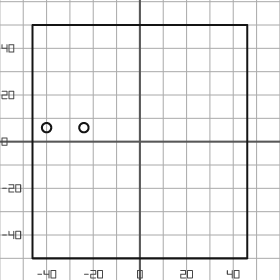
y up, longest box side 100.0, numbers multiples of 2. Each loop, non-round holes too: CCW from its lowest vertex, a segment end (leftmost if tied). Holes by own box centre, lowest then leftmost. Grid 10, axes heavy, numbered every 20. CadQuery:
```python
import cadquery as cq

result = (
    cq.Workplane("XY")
    .moveTo(-46.0, -50.0)
    .lineTo(46.0, -50.0)
    .lineTo(46.0, 50.0)
    .lineTo(-46.0, 50.0)
    .close()
    .moveTo(-40.0, 6.0)
    .circle(2.0)
    .moveTo(-24.0, 6.0)
    .circle(2.0)
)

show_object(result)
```